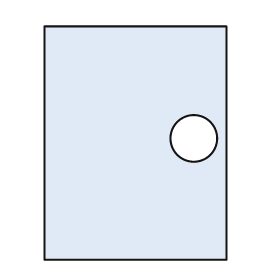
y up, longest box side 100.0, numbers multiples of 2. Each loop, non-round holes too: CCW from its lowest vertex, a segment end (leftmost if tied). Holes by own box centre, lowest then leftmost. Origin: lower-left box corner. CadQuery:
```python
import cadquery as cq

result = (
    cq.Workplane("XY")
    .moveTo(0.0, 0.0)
    .lineTo(78.0, 0.0)
    .lineTo(78.0, 100.0)
    .lineTo(0.0, 100.0)
    .close()
    .moveTo(64.0, 52.0)
    .circle(10.0)
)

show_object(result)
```